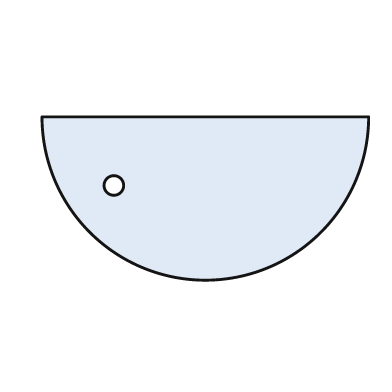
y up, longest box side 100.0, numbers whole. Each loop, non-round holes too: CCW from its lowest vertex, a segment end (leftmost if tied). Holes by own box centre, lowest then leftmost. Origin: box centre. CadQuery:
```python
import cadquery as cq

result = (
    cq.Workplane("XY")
    .moveTo(-50.0, 25.0)
    .threePointArc((0.0, -25.0), (50.0, 25.0))
    .close()
    .moveTo(-28.0, 4.0)
    .circle(3.0)
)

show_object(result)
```